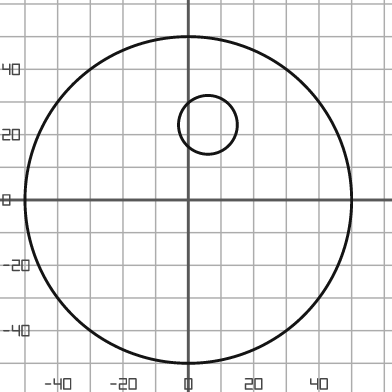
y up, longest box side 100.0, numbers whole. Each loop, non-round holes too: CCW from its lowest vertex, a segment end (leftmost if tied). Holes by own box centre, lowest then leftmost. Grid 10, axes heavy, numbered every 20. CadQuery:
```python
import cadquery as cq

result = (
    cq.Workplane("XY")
    .moveTo(0.0, 0.0)
    .circle(50.0)
    .moveTo(6.0, 23.0)
    .circle(9.0)
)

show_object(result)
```